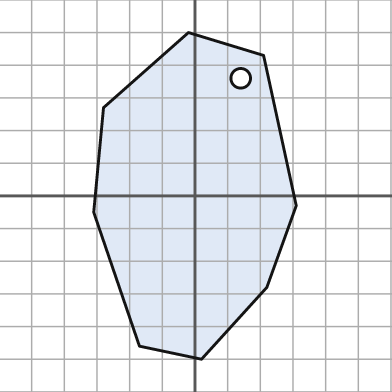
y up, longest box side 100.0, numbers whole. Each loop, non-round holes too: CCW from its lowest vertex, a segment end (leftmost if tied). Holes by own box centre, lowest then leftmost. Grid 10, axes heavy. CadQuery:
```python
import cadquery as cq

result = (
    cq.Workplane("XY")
    .moveTo(2.0, -50.0)
    .lineTo(22.0, -28.0)
    .lineTo(31.0, -3.0)
    .lineTo(21.0, 43.0)
    .lineTo(-2.0, 50.0)
    .lineTo(-28.0, 27.0)
    .lineTo(-31.0, -5.0)
    .lineTo(-17.0, -46.0)
    .close()
    .moveTo(14.0, 36.0)
    .circle(3.0)
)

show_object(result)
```